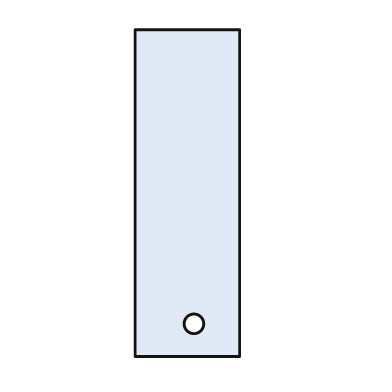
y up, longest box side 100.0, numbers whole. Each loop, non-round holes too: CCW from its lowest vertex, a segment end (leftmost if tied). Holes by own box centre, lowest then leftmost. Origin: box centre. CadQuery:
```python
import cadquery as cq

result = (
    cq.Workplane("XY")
    .moveTo(-16.0, -50.0)
    .lineTo(16.0, -50.0)
    .lineTo(16.0, 50.0)
    .lineTo(-16.0, 50.0)
    .close()
    .moveTo(2.0, -40.0)
    .circle(3.0)
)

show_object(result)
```